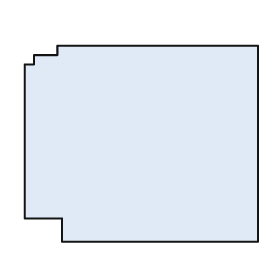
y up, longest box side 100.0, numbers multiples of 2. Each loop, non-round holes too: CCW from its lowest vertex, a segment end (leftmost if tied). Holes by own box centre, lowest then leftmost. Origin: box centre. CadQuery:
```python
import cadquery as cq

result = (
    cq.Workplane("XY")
    .moveTo(-34.0, -42.0)
    .lineTo(50.0, -42.0)
    .lineTo(50.0, 42.0)
    .lineTo(-36.0, 42.0)
    .lineTo(-36.0, 38.0)
    .lineTo(-46.0, 38.0)
    .lineTo(-46.0, 34.0)
    .lineTo(-50.0, 34.0)
    .lineTo(-50.0, -32.0)
    .lineTo(-34.0, -32.0)
    .close()
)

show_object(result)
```